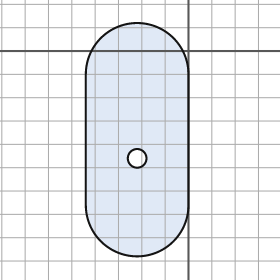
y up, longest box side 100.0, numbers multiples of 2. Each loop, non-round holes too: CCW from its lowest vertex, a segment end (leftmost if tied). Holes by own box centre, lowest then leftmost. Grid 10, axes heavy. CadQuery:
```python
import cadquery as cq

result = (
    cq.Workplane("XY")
    .moveTo(-44.0, -66.0)
    .threePointArc((-22.0, -88.0), (0.0, -66.0))
    .lineTo(0.0, -10.0)
    .threePointArc((-22.0, 12.0), (-44.0, -10.0))
    .close()
    .moveTo(-22.0, -46.0)
    .circle(4.0)
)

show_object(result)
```